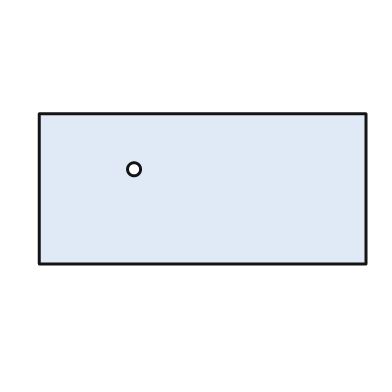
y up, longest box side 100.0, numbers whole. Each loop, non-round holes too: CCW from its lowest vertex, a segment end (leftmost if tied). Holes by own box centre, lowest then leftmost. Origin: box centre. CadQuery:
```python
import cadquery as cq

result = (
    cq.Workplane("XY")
    .moveTo(-50.0, -23.0)
    .lineTo(50.0, -23.0)
    .lineTo(50.0, 23.0)
    .lineTo(-50.0, 23.0)
    .close()
    .moveTo(-21.0, 6.0)
    .circle(2.0)
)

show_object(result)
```